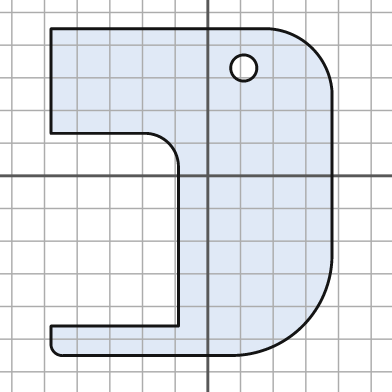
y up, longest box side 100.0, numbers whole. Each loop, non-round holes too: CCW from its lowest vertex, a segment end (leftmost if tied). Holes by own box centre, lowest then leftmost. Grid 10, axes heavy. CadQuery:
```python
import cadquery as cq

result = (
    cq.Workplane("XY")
    .moveTo(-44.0, -55.0)
    .lineTo(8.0, -55.0)
    .threePointArc((29.0, -46.0), (38.0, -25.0))
    .lineTo(38.0, 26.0)
    .threePointArc((32.0, 39.0), (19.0, 45.0))
    .lineTo(-48.0, 45.0)
    .lineTo(-48.0, 13.0)
    .lineTo(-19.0, 13.0)
    .threePointArc((-12.0, 10.0), (-9.0, 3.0))
    .lineTo(-9.0, -46.0)
    .lineTo(-48.0, -46.0)
    .lineTo(-48.0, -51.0)
    .threePointArc((-47.0, -54.0), (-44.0, -55.0))
    .close()
    .moveTo(11.0, 33.0)
    .circle(4.0)
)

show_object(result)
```